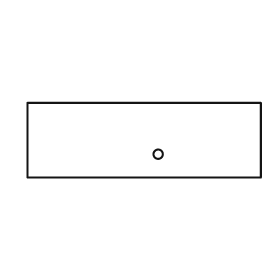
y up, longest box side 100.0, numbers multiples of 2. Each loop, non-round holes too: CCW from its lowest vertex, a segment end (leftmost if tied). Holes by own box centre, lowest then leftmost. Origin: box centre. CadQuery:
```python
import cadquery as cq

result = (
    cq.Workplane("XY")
    .moveTo(-50.0, -16.0)
    .lineTo(50.0, -16.0)
    .lineTo(50.0, 16.0)
    .lineTo(-50.0, 16.0)
    .close()
    .moveTo(6.0, -6.0)
    .circle(2.0)
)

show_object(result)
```